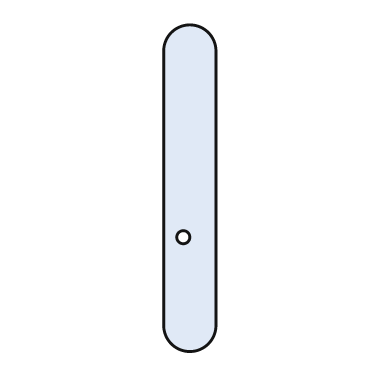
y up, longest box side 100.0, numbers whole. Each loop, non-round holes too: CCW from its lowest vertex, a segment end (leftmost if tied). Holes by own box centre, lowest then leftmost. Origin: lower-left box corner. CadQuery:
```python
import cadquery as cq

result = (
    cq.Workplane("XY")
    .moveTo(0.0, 8.0)
    .threePointArc((8.0, 0.0), (16.0, 8.0))
    .lineTo(16.0, 92.0)
    .threePointArc((8.0, 100.0), (0.0, 92.0))
    .close()
    .moveTo(6.0, 35.0)
    .circle(2.0)
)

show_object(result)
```